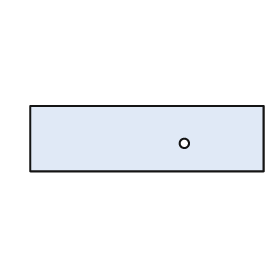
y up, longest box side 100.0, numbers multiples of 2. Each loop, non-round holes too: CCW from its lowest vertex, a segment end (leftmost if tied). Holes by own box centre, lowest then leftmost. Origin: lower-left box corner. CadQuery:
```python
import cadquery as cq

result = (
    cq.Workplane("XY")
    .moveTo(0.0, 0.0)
    .lineTo(100.0, 0.0)
    .lineTo(100.0, 28.0)
    .lineTo(0.0, 28.0)
    .close()
    .moveTo(66.0, 12.0)
    .circle(2.0)
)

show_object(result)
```